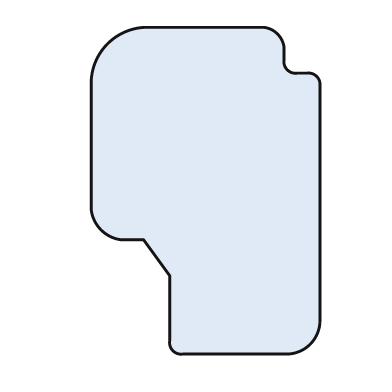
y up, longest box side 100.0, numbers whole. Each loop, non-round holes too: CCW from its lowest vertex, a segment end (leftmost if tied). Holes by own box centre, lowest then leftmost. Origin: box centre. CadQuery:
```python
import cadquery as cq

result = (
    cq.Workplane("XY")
    .moveTo(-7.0, -50.0)
    .lineTo(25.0, -50.0)
    .threePointArc((32.0, -47.0), (35.0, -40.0))
    .lineTo(35.0, 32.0)
    .threePointArc((34.0, 35.0), (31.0, 36.0))
    .lineTo(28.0, 36.0)
    .threePointArc((25.0, 37.0), (24.0, 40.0))
    .lineTo(24.0, 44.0)
    .threePointArc((22.0, 48.0), (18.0, 50.0))
    .lineTo(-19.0, 50.0)
    .threePointArc((-30.0, 45.0), (-35.0, 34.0))
    .lineTo(-35.0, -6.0)
    .threePointArc((-32.0, -12.0), (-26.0, -15.0))
    .lineTo(-19.0, -15.0)
    .lineTo(-11.0, -26.0)
    .lineTo(-11.0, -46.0)
    .threePointArc((-10.0, -49.0), (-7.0, -50.0))
    .close()
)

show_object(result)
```